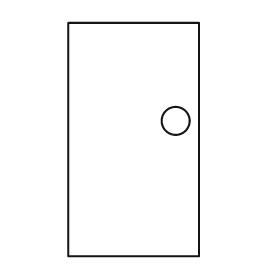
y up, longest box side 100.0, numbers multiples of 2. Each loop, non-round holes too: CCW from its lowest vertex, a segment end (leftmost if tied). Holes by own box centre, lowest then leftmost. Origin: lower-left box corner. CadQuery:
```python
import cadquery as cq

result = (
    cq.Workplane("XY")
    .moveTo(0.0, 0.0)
    .lineTo(56.0, 0.0)
    .lineTo(56.0, 100.0)
    .lineTo(0.0, 100.0)
    .close()
    .moveTo(46.0, 58.0)
    .circle(6.0)
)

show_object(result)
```